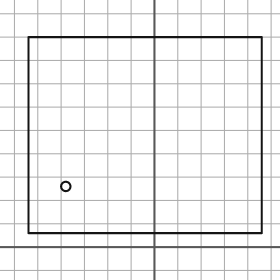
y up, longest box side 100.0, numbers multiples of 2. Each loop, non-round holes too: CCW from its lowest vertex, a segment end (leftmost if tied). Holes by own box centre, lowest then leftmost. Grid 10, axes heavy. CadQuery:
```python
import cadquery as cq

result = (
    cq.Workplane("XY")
    .moveTo(-54.0, 6.0)
    .lineTo(46.0, 6.0)
    .lineTo(46.0, 90.0)
    .lineTo(-54.0, 90.0)
    .close()
    .moveTo(-38.0, 26.0)
    .circle(2.0)
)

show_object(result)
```